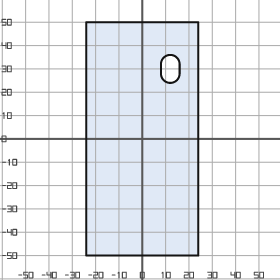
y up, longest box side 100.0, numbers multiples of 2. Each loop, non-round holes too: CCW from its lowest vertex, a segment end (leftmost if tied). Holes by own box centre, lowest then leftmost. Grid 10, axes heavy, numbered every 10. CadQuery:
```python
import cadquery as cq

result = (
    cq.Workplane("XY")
    .moveTo(-24.0, -50.0)
    .lineTo(24.0, -50.0)
    .lineTo(24.0, 50.0)
    .lineTo(-24.0, 50.0)
    .close()
    .moveTo(8.0, 28.0)
    .threePointArc((12.0, 24.0), (16.0, 28.0))
    .lineTo(16.0, 32.0)
    .threePointArc((12.0, 36.0), (8.0, 32.0))
    .close()
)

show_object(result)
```